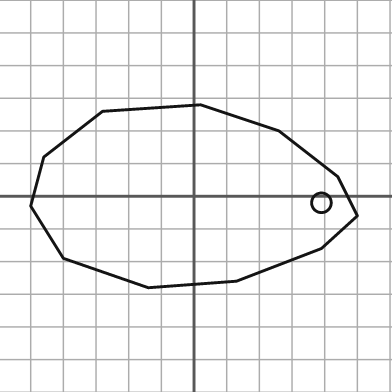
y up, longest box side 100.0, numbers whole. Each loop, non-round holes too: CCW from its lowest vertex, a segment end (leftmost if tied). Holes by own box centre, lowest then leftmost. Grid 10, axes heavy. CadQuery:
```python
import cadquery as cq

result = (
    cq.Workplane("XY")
    .moveTo(-14.0, -28.0)
    .lineTo(13.0, -26.0)
    .lineTo(39.0, -16.0)
    .lineTo(50.0, -6.0)
    .lineTo(44.0, 6.0)
    .lineTo(26.0, 20.0)
    .lineTo(2.0, 28.0)
    .lineTo(-28.0, 26.0)
    .lineTo(-46.0, 12.0)
    .lineTo(-50.0, -3.0)
    .lineTo(-40.0, -19.0)
    .close()
    .moveTo(39.0, -2.0)
    .circle(3.0)
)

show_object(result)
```